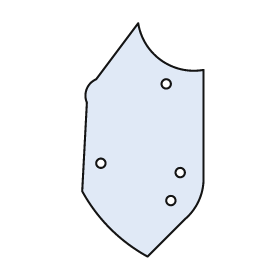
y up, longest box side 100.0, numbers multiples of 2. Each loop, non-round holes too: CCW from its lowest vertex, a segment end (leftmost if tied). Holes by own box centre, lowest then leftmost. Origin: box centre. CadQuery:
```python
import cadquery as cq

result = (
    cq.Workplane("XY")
    .moveTo(2.0, -50.0)
    .lineTo(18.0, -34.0)
    .threePointArc((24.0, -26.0), (26.0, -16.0))
    .lineTo(26.0, 30.0)
    .threePointArc((8.0, 34.0), (-2.0, 50.0))
    .lineTo(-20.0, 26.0)
    .threePointArc((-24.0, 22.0), (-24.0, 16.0))
    .lineTo(-26.0, -22.0)
    .threePointArc((-14.0, -38.0), (2.0, -50.0))
    .close()
    .moveTo(12.0, -26.0)
    .circle(2.0)
    .moveTo(16.0, -14.0)
    .circle(2.0)
    .moveTo(-18.0, -10.0)
    .circle(2.0)
    .moveTo(10.0, 24.0)
    .circle(2.0)
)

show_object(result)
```